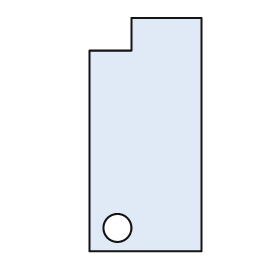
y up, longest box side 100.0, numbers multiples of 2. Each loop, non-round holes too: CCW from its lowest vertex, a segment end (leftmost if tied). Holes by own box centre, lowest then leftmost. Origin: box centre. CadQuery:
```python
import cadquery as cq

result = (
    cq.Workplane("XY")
    .moveTo(-24.0, -50.0)
    .lineTo(24.0, -50.0)
    .lineTo(24.0, 50.0)
    .lineTo(-6.0, 50.0)
    .lineTo(-6.0, 36.0)
    .lineTo(-24.0, 36.0)
    .close()
    .moveTo(-12.0, -40.0)
    .circle(6.0)
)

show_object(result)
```